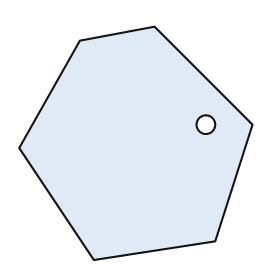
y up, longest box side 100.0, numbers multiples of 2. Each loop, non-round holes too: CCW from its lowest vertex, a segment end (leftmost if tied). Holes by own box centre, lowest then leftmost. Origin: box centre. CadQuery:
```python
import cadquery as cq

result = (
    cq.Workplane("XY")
    .moveTo(-18.0, -50.0)
    .lineTo(34.0, -42.0)
    .lineTo(50.0, 8.0)
    .lineTo(8.0, 50.0)
    .lineTo(-24.0, 44.0)
    .lineTo(-50.0, -2.0)
    .close()
    .moveTo(30.0, 8.0)
    .circle(4.0)
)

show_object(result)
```